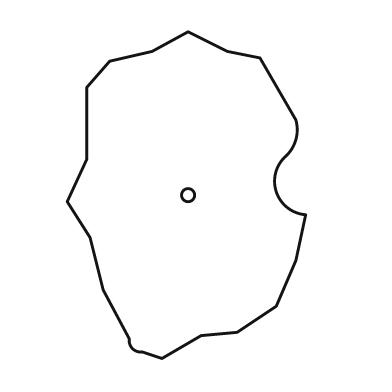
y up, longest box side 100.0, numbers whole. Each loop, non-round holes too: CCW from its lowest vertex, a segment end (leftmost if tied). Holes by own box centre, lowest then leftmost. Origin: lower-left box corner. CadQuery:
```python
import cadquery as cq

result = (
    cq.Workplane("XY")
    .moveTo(29.0, 0.0)
    .lineTo(41.0, 7.0)
    .lineTo(52.0, 8.0)
    .lineTo(64.0, 16.0)
    .lineTo(70.0, 30.0)
    .lineTo(73.0, 44.0)
    .threePointArc((64.0, 51.0), (67.0, 62.0))
    .threePointArc((70.0, 67.0), (70.0, 73.0))
    .lineTo(59.0, 92.0)
    .lineTo(49.0, 94.0)
    .lineTo(37.0, 100.0)
    .lineTo(26.0, 94.0)
    .lineTo(13.0, 91.0)
    .lineTo(6.0, 83.0)
    .lineTo(6.0, 61.0)
    .lineTo(0.0, 48.0)
    .lineTo(7.0, 37.0)
    .lineTo(11.0, 21.0)
    .lineTo(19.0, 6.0)
    .threePointArc((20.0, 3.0), (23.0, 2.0))
    .close()
    .moveTo(37.0, 50.0)
    .circle(2.0)
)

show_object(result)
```